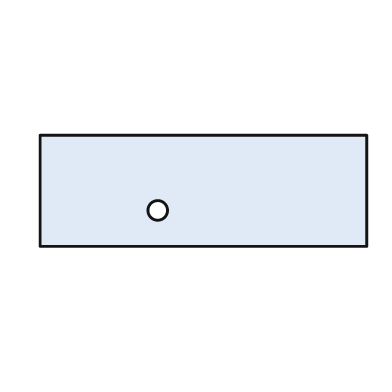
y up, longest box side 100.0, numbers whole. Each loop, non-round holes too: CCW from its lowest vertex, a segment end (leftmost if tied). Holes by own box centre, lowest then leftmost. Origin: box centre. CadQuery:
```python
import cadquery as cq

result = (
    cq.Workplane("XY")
    .moveTo(-50.0, -17.0)
    .lineTo(50.0, -17.0)
    .lineTo(50.0, 17.0)
    .lineTo(-50.0, 17.0)
    .close()
    .moveTo(-14.0, -6.0)
    .circle(3.0)
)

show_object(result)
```